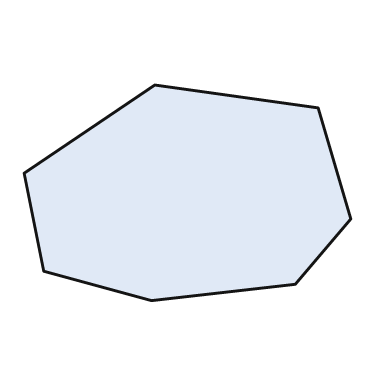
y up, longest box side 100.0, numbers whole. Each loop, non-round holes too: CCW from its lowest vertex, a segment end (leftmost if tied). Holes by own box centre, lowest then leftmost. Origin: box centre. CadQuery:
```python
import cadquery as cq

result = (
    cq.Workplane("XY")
    .moveTo(-11.0, -33.0)
    .lineTo(33.0, -28.0)
    .lineTo(50.0, -8.0)
    .lineTo(40.0, 26.0)
    .lineTo(-10.0, 33.0)
    .lineTo(-50.0, 6.0)
    .lineTo(-44.0, -24.0)
    .close()
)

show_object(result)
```